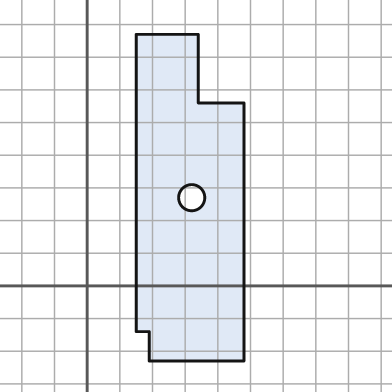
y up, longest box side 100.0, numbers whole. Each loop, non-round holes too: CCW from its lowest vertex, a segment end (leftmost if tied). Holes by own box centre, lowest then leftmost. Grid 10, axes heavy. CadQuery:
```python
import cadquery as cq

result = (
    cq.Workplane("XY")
    .moveTo(19.0, -23.0)
    .lineTo(48.0, -23.0)
    .lineTo(48.0, 56.0)
    .lineTo(34.0, 56.0)
    .lineTo(34.0, 77.0)
    .lineTo(15.0, 77.0)
    .lineTo(15.0, -14.0)
    .lineTo(19.0, -14.0)
    .close()
    .moveTo(32.0, 27.0)
    .circle(4.0)
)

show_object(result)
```